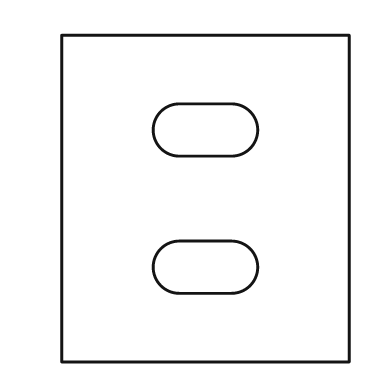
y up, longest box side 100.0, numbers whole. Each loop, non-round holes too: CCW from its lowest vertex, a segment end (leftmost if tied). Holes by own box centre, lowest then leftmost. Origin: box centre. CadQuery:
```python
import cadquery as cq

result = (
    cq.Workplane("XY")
    .moveTo(-44.0, -50.0)
    .lineTo(44.0, -50.0)
    .lineTo(44.0, 50.0)
    .lineTo(-44.0, 50.0)
    .close()
    .moveTo(-8.0, -29.0)
    .lineTo(8.0, -29.0)
    .threePointArc((16.0, -21.0), (8.0, -13.0))
    .lineTo(-8.0, -13.0)
    .threePointArc((-16.0, -21.0), (-8.0, -29.0))
    .close()
    .moveTo(-8.0, 13.0)
    .lineTo(8.0, 13.0)
    .threePointArc((16.0, 21.0), (8.0, 29.0))
    .lineTo(-8.0, 29.0)
    .threePointArc((-16.0, 21.0), (-8.0, 13.0))
    .close()
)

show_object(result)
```